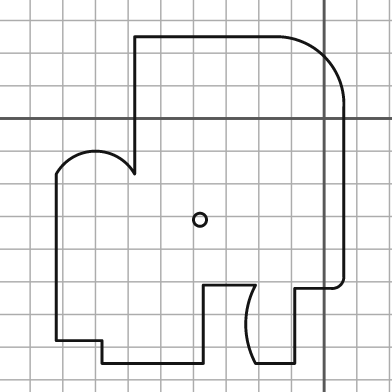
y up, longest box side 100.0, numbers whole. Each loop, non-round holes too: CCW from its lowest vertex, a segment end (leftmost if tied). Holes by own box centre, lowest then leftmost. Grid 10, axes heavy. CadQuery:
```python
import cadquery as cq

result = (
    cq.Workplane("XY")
    .moveTo(-68.0, -75.0)
    .lineTo(-37.0, -75.0)
    .lineTo(-37.0, -51.0)
    .lineTo(-21.0, -51.0)
    .threePointArc((-24.0, -63.0), (-21.0, -75.0))
    .lineTo(-9.0, -75.0)
    .lineTo(-9.0, -52.0)
    .lineTo(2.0, -52.0)
    .threePointArc((5.0, -51.0), (6.0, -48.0))
    .lineTo(6.0, 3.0)
    .threePointArc((0.0, 19.0), (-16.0, 25.0))
    .lineTo(-58.0, 25.0)
    .lineTo(-58.0, -17.0)
    .threePointArc((-70.0, -10.0), (-82.0, -17.0))
    .lineTo(-82.0, -68.0)
    .lineTo(-68.0, -68.0)
    .close()
    .moveTo(-38.0, -31.0)
    .circle(2.0)
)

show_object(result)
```